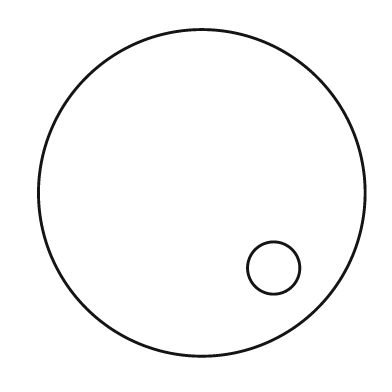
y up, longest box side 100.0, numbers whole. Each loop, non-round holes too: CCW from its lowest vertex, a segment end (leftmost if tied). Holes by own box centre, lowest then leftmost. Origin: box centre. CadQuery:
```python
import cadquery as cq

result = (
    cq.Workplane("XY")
    .moveTo(0.0, 0.0)
    .circle(50.0)
    .moveTo(22.0, -23.0)
    .circle(8.0)
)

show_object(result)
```